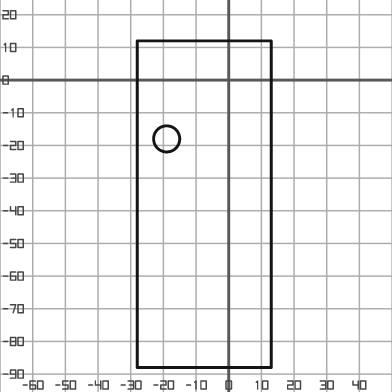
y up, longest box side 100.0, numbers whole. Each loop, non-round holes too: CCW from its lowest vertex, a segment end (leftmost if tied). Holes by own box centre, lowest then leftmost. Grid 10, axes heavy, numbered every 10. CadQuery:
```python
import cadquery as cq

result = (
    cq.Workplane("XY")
    .moveTo(-28.0, -88.0)
    .lineTo(13.0, -88.0)
    .lineTo(13.0, 12.0)
    .lineTo(-28.0, 12.0)
    .close()
    .moveTo(-19.0, -18.0)
    .circle(4.0)
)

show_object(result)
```